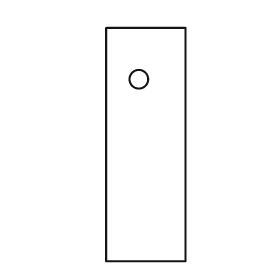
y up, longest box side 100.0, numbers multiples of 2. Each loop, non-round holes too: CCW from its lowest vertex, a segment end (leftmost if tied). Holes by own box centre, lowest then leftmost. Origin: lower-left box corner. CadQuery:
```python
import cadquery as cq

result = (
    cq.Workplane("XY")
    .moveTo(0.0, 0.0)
    .lineTo(34.0, 0.0)
    .lineTo(34.0, 100.0)
    .lineTo(0.0, 100.0)
    .close()
    .moveTo(14.0, 78.0)
    .circle(4.0)
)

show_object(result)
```